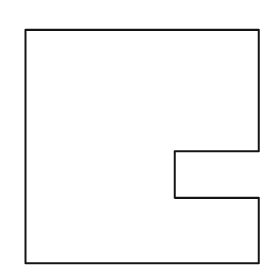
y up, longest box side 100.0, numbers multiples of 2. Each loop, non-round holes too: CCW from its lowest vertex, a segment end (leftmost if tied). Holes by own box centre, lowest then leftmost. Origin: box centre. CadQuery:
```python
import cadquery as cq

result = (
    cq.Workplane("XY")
    .moveTo(-50.0, -50.0)
    .lineTo(50.0, -50.0)
    .lineTo(50.0, -22.0)
    .lineTo(14.0, -22.0)
    .lineTo(14.0, -2.0)
    .lineTo(50.0, -2.0)
    .lineTo(50.0, 50.0)
    .lineTo(-50.0, 50.0)
    .close()
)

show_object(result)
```